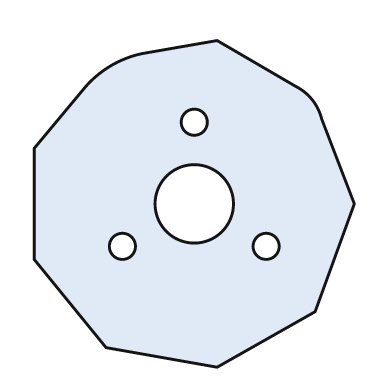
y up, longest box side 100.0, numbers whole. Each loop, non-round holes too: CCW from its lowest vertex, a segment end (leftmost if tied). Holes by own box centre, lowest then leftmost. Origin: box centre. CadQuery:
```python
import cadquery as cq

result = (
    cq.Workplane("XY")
    .moveTo(7.0, -50.0)
    .lineTo(37.0, -33.0)
    .lineTo(49.0, 0.0)
    .lineTo(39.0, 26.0)
    .threePointArc((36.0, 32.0), (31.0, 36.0))
    .lineTo(7.0, 50.0)
    .lineTo(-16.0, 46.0)
    .threePointArc((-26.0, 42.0), (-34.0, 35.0))
    .lineTo(-49.0, 17.0)
    .lineTo(-49.0, -17.0)
    .lineTo(-27.0, -44.0)
    .close()
    .moveTo(-22.0, -13.0)
    .circle(4.0)
    .moveTo(22.0, -13.0)
    .circle(4.0)
    .moveTo(0.0, 0.0)
    .circle(12.0)
    .moveTo(0.0, 25.0)
    .circle(4.0)
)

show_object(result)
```